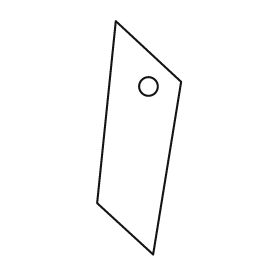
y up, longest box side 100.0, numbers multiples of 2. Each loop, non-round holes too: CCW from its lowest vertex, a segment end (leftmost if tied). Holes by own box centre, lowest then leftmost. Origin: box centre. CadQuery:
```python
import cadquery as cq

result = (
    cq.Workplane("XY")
    .moveTo(6.0, -50.0)
    .lineTo(18.0, 24.0)
    .lineTo(-10.0, 50.0)
    .lineTo(-18.0, -28.0)
    .close()
    .moveTo(4.0, 22.0)
    .circle(4.0)
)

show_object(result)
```